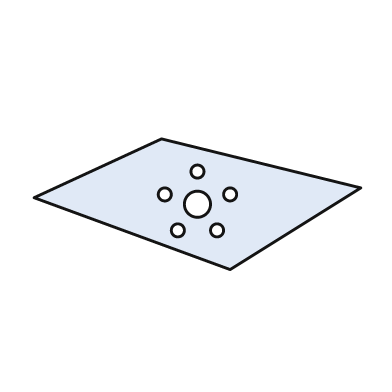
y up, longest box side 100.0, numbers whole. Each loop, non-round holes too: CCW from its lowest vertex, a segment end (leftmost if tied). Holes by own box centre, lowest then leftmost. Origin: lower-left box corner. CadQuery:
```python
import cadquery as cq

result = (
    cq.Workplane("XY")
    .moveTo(60.0, 0.0)
    .lineTo(100.0, 25.0)
    .lineTo(39.0, 40.0)
    .lineTo(0.0, 22.0)
    .close()
    .moveTo(44.0, 12.0)
    .circle(2.0)
    .moveTo(56.0, 12.0)
    .circle(2.0)
    .moveTo(50.0, 20.0)
    .circle(4.0)
    .moveTo(40.0, 23.0)
    .circle(2.0)
    .moveTo(60.0, 23.0)
    .circle(2.0)
    .moveTo(50.0, 30.0)
    .circle(2.0)
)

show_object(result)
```